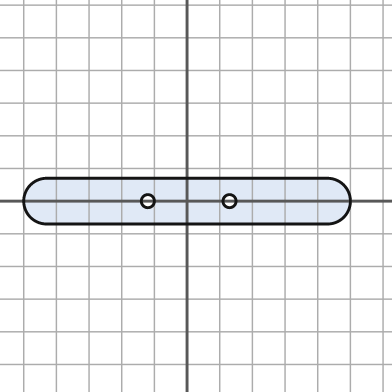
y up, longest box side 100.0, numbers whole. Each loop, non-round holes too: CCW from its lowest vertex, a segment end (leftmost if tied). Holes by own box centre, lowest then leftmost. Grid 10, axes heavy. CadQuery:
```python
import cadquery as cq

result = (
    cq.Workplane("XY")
    .moveTo(-43.0, -7.0)
    .lineTo(43.0, -7.0)
    .threePointArc((50.0, 0.0), (43.0, 7.0))
    .lineTo(-43.0, 7.0)
    .threePointArc((-50.0, 0.0), (-43.0, -7.0))
    .close()
    .moveTo(-12.0, 0.0)
    .circle(2.0)
    .moveTo(13.0, 0.0)
    .circle(2.0)
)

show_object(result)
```